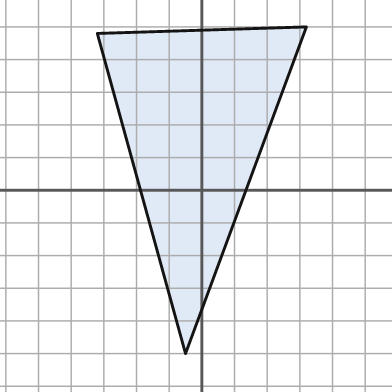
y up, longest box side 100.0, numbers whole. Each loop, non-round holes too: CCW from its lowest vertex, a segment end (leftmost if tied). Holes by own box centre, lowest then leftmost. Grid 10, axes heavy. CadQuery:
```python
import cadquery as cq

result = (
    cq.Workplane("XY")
    .moveTo(-5.0, -50.0)
    .lineTo(32.0, 50.0)
    .lineTo(-32.0, 48.0)
    .close()
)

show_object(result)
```